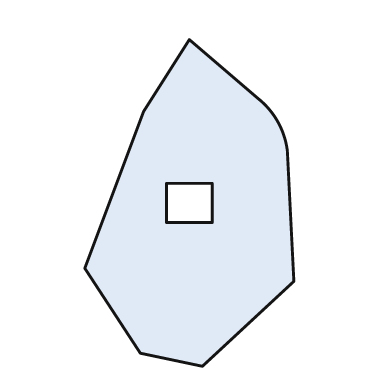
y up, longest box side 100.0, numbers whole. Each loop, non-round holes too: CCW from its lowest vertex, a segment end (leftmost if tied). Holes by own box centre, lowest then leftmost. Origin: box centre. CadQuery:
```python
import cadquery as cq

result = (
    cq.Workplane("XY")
    .moveTo(4.0, -50.0)
    .lineTo(32.0, -24.0)
    .lineTo(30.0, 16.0)
    .threePointArc((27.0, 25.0), (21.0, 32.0))
    .lineTo(0.0, 50.0)
    .lineTo(-14.0, 28.0)
    .lineTo(-32.0, -20.0)
    .lineTo(-15.0, -46.0)
    .close()
    .moveTo(-7.0, -6.0)
    .lineTo(7.0, -6.0)
    .lineTo(7.0, 6.0)
    .lineTo(-7.0, 6.0)
    .close()
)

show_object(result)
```